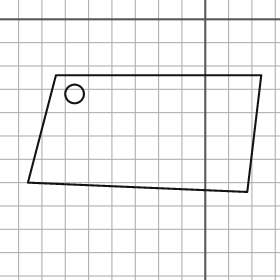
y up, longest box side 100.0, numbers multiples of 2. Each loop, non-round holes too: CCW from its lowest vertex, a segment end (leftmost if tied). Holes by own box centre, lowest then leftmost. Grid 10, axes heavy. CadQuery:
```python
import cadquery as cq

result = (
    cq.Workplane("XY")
    .moveTo(18.0, -74.0)
    .lineTo(24.0, -24.0)
    .lineTo(-64.0, -24.0)
    .lineTo(-76.0, -70.0)
    .close()
    .moveTo(-56.0, -32.0)
    .circle(4.0)
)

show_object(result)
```